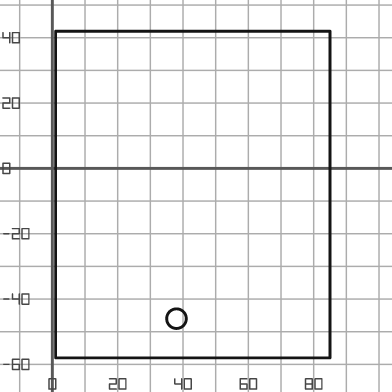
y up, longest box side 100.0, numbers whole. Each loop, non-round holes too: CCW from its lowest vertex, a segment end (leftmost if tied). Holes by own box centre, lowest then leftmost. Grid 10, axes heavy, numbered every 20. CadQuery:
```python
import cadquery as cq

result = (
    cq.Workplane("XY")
    .moveTo(1.0, -58.0)
    .lineTo(85.0, -58.0)
    .lineTo(85.0, 42.0)
    .lineTo(1.0, 42.0)
    .close()
    .moveTo(38.0, -46.0)
    .circle(3.0)
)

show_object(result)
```